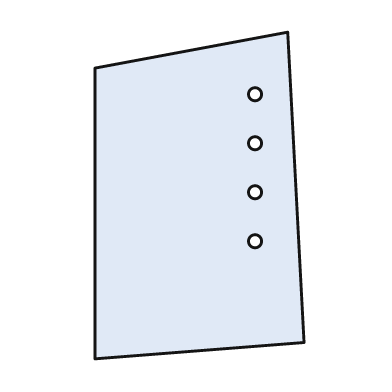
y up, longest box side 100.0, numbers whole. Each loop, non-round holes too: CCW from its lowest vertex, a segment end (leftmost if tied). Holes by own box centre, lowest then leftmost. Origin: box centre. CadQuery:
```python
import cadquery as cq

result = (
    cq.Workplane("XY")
    .moveTo(-32.0, -50.0)
    .lineTo(32.0, -45.0)
    .lineTo(27.0, 50.0)
    .lineTo(-32.0, 39.0)
    .close()
    .moveTo(17.0, -14.0)
    .circle(2.0)
    .moveTo(17.0, 1.0)
    .circle(2.0)
    .moveTo(17.0, 16.0)
    .circle(2.0)
    .moveTo(17.0, 31.0)
    .circle(2.0)
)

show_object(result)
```